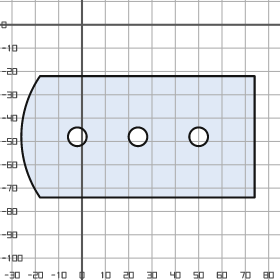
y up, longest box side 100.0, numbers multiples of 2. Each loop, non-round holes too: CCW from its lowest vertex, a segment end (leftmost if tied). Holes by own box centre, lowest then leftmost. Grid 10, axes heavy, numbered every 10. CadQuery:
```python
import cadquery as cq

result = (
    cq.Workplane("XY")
    .moveTo(-18.0, -74.0)
    .lineTo(74.0, -74.0)
    .lineTo(74.0, -22.0)
    .lineTo(-18.0, -22.0)
    .threePointArc((-26.0, -48.0), (-18.0, -74.0))
    .close()
    .moveTo(-2.0, -48.0)
    .circle(4.0)
    .moveTo(24.0, -48.0)
    .circle(4.0)
    .moveTo(50.0, -48.0)
    .circle(4.0)
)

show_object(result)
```